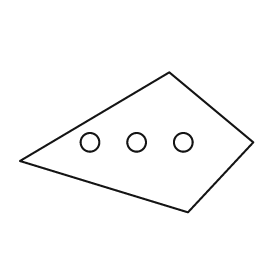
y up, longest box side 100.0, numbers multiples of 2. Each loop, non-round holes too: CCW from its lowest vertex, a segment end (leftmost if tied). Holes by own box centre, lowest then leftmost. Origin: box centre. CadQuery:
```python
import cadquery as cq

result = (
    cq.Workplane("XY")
    .moveTo(22.0, -30.0)
    .lineTo(50.0, 0.0)
    .lineTo(14.0, 30.0)
    .lineTo(-50.0, -8.0)
    .close()
    .moveTo(-20.0, 0.0)
    .circle(4.0)
    .moveTo(0.0, 0.0)
    .circle(4.0)
    .moveTo(20.0, 0.0)
    .circle(4.0)
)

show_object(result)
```